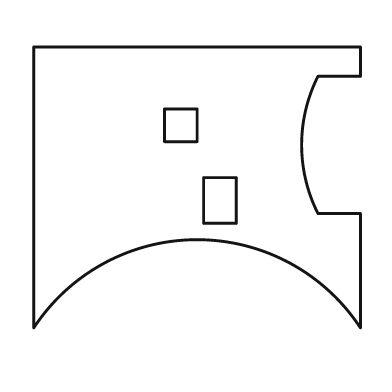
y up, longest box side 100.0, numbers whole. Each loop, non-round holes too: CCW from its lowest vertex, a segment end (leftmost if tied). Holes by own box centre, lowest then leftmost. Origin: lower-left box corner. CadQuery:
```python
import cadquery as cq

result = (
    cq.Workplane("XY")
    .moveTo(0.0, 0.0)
    .threePointArc((50.0, 27.0), (100.0, 0.0))
    .lineTo(100.0, 35.0)
    .lineTo(87.0, 35.0)
    .threePointArc((82.0, 56.0), (87.0, 77.0))
    .lineTo(100.0, 77.0)
    .lineTo(100.0, 86.0)
    .lineTo(0.0, 86.0)
    .close()
    .moveTo(52.0, 32.0)
    .lineTo(62.0, 32.0)
    .lineTo(62.0, 46.0)
    .lineTo(52.0, 46.0)
    .close()
    .moveTo(40.0, 57.0)
    .lineTo(50.0, 57.0)
    .lineTo(50.0, 67.0)
    .lineTo(40.0, 67.0)
    .close()
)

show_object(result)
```